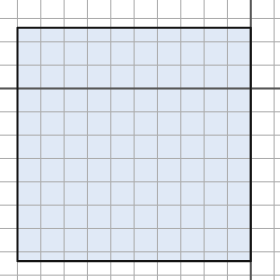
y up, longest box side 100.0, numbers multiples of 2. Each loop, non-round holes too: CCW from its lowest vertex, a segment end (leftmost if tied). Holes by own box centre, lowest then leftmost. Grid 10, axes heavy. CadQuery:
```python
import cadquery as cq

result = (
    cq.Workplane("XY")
    .moveTo(-100.0, -74.0)
    .lineTo(0.0, -74.0)
    .lineTo(0.0, 26.0)
    .lineTo(-100.0, 26.0)
    .close()
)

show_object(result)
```